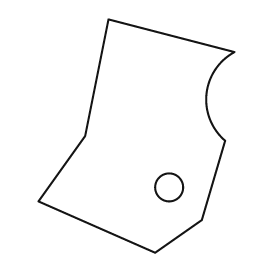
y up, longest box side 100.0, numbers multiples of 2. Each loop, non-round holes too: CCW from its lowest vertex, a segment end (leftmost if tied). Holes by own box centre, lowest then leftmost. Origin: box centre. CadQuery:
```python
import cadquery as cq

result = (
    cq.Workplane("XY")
    .moveTo(8.0, -50.0)
    .lineTo(28.0, -36.0)
    .lineTo(38.0, -2.0)
    .threePointArc((30.0, 18.0), (42.0, 36.0))
    .lineTo(-12.0, 50.0)
    .lineTo(-22.0, 0.0)
    .lineTo(-42.0, -28.0)
    .close()
    .moveTo(14.0, -22.0)
    .circle(6.0)
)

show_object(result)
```